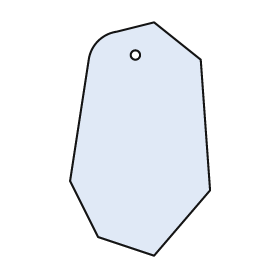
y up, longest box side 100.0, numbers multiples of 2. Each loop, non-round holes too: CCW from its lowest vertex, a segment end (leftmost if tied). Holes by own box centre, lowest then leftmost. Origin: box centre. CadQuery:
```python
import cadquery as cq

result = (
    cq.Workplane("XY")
    .moveTo(6.0, -50.0)
    .lineTo(30.0, -22.0)
    .lineTo(26.0, 34.0)
    .lineTo(6.0, 50.0)
    .lineTo(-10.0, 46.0)
    .threePointArc((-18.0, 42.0), (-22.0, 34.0))
    .lineTo(-30.0, -18.0)
    .lineTo(-18.0, -42.0)
    .close()
    .moveTo(-2.0, 36.0)
    .circle(2.0)
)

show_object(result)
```